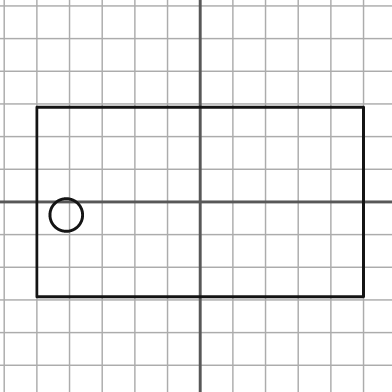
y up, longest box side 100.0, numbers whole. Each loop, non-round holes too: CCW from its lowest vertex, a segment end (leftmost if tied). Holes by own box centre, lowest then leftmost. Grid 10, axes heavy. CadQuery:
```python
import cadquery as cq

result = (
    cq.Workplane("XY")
    .moveTo(-50.0, -29.0)
    .lineTo(50.0, -29.0)
    .lineTo(50.0, 29.0)
    .lineTo(-50.0, 29.0)
    .close()
    .moveTo(-41.0, -4.0)
    .circle(5.0)
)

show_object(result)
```